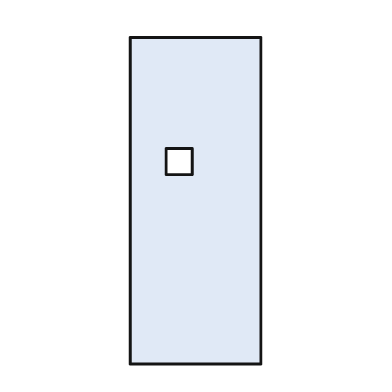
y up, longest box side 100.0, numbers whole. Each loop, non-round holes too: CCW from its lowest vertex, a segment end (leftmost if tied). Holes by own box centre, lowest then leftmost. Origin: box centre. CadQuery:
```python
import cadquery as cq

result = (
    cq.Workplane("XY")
    .moveTo(-20.0, -50.0)
    .lineTo(20.0, -50.0)
    .lineTo(20.0, 50.0)
    .lineTo(-20.0, 50.0)
    .close()
    .moveTo(-9.0, 8.0)
    .lineTo(-1.0, 8.0)
    .lineTo(-1.0, 16.0)
    .lineTo(-9.0, 16.0)
    .close()
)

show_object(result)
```